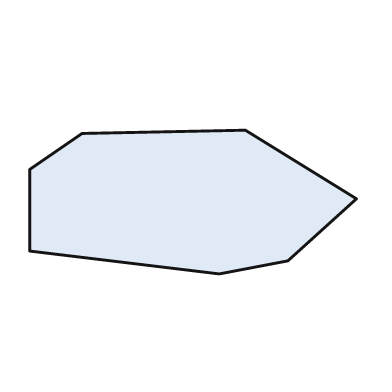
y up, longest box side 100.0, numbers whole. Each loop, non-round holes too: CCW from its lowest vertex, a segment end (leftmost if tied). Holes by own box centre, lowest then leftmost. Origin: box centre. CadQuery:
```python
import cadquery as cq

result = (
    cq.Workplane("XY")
    .moveTo(8.0, -22.0)
    .lineTo(29.0, -18.0)
    .lineTo(50.0, 1.0)
    .lineTo(16.0, 22.0)
    .lineTo(-34.0, 21.0)
    .lineTo(-50.0, 10.0)
    .lineTo(-50.0, -15.0)
    .close()
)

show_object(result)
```